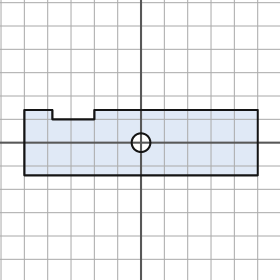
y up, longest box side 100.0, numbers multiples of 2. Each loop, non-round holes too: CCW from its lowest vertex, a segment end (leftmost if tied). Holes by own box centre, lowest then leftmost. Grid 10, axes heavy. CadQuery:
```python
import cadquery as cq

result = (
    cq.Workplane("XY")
    .moveTo(-50.0, -14.0)
    .lineTo(50.0, -14.0)
    .lineTo(50.0, 14.0)
    .lineTo(-20.0, 14.0)
    .lineTo(-20.0, 10.0)
    .lineTo(-38.0, 10.0)
    .lineTo(-38.0, 14.0)
    .lineTo(-50.0, 14.0)
    .close()
    .moveTo(0.0, 0.0)
    .circle(4.0)
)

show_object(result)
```